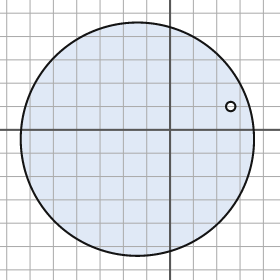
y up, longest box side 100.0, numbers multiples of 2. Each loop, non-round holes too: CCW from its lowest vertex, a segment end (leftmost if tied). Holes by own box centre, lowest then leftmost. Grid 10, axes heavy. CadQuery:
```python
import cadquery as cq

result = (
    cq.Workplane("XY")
    .moveTo(-14.0, -4.0)
    .circle(50.0)
    .moveTo(26.0, 10.0)
    .circle(2.0)
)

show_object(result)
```